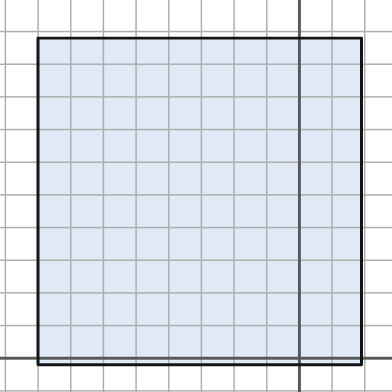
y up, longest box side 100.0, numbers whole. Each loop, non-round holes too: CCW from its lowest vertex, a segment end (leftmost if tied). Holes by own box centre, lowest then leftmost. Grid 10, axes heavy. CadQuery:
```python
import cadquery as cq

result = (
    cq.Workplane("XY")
    .moveTo(-80.0, -2.0)
    .lineTo(19.0, -2.0)
    .lineTo(19.0, 98.0)
    .lineTo(-80.0, 98.0)
    .close()
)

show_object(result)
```